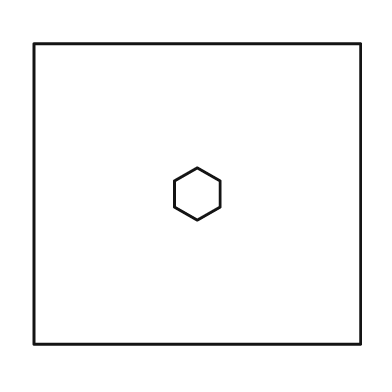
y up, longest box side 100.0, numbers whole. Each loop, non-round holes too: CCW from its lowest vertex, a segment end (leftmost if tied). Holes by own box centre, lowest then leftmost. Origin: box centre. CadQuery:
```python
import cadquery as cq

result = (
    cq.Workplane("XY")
    .moveTo(-50.0, -46.0)
    .lineTo(50.0, -46.0)
    .lineTo(50.0, 46.0)
    .lineTo(-50.0, 46.0)
    .close()
    .moveTo(0.0, -8.0)
    .lineTo(7.0, -4.0)
    .lineTo(7.0, 4.0)
    .lineTo(0.0, 8.0)
    .lineTo(-7.0, 4.0)
    .lineTo(-7.0, -4.0)
    .close()
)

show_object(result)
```